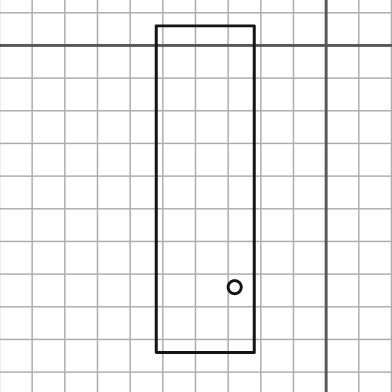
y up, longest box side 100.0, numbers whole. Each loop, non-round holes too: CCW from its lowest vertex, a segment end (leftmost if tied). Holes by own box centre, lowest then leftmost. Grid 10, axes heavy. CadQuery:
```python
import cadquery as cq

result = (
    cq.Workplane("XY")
    .moveTo(-52.0, -94.0)
    .lineTo(-22.0, -94.0)
    .lineTo(-22.0, 6.0)
    .lineTo(-52.0, 6.0)
    .close()
    .moveTo(-28.0, -74.0)
    .circle(2.0)
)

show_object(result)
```